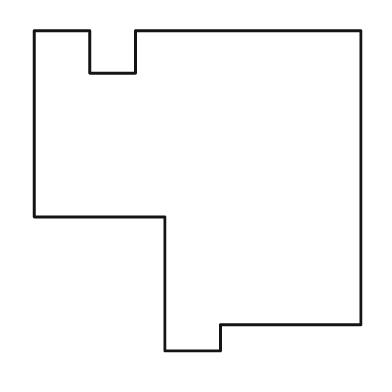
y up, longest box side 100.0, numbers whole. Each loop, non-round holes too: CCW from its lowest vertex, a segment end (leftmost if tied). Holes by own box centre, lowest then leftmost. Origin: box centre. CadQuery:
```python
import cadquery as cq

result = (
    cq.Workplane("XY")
    .moveTo(-10.0, -49.0)
    .lineTo(7.0, -49.0)
    .lineTo(7.0, -41.0)
    .lineTo(50.0, -41.0)
    .lineTo(50.0, 49.0)
    .lineTo(-19.0, 49.0)
    .lineTo(-19.0, 36.0)
    .lineTo(-33.0, 36.0)
    .lineTo(-33.0, 49.0)
    .lineTo(-50.0, 49.0)
    .lineTo(-50.0, -8.0)
    .lineTo(-10.0, -8.0)
    .close()
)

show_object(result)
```